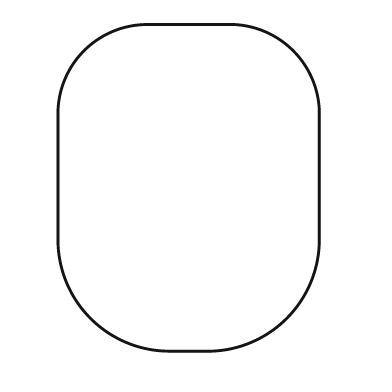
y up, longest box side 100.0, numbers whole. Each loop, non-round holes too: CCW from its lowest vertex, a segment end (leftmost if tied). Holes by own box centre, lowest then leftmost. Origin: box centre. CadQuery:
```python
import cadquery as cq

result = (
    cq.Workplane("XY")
    .moveTo(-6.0, -50.0)
    .lineTo(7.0, -50.0)
    .threePointArc((30.0, -40.0), (40.0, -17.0))
    .lineTo(40.0, 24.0)
    .threePointArc((32.0, 42.0), (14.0, 50.0))
    .lineTo(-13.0, 50.0)
    .threePointArc((-32.0, 42.0), (-40.0, 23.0))
    .lineTo(-40.0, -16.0)
    .threePointArc((-30.0, -40.0), (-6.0, -50.0))
    .close()
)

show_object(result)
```